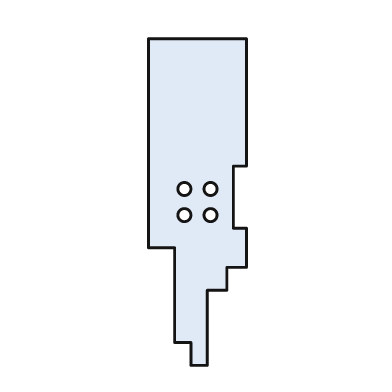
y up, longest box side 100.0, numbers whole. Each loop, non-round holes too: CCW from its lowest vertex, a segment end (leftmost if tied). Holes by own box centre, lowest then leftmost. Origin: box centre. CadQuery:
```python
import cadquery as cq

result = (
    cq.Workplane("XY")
    .moveTo(-2.0, -50.0)
    .lineTo(3.0, -50.0)
    .lineTo(3.0, -27.0)
    .lineTo(9.0, -27.0)
    .lineTo(9.0, -20.0)
    .lineTo(15.0, -20.0)
    .lineTo(15.0, -8.0)
    .lineTo(11.0, -8.0)
    .lineTo(11.0, 11.0)
    .lineTo(15.0, 11.0)
    .lineTo(15.0, 50.0)
    .lineTo(-15.0, 50.0)
    .lineTo(-15.0, -14.0)
    .lineTo(-7.0, -14.0)
    .lineTo(-7.0, -43.0)
    .lineTo(-2.0, -43.0)
    .close()
    .moveTo(-4.0, -4.0)
    .circle(2.0)
    .moveTo(4.0, -4.0)
    .circle(2.0)
    .moveTo(-4.0, 4.0)
    .circle(2.0)
    .moveTo(4.0, 4.0)
    .circle(2.0)
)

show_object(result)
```